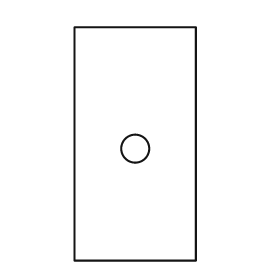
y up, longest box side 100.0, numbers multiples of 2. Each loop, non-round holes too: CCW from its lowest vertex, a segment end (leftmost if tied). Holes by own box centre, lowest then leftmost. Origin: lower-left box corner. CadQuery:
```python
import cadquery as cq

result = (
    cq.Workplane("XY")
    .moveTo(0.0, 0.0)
    .lineTo(52.0, 0.0)
    .lineTo(52.0, 100.0)
    .lineTo(0.0, 100.0)
    .close()
    .moveTo(26.0, 48.0)
    .circle(6.0)
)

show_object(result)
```